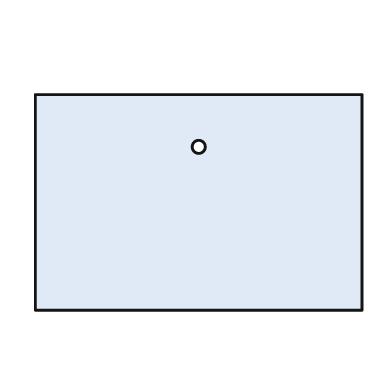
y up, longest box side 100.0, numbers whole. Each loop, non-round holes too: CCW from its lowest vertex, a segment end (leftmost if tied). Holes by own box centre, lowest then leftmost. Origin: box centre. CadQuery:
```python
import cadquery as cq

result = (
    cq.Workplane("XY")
    .moveTo(-50.0, -33.0)
    .lineTo(50.0, -33.0)
    .lineTo(50.0, 33.0)
    .lineTo(-50.0, 33.0)
    .close()
    .moveTo(0.0, 17.0)
    .circle(2.0)
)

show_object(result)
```